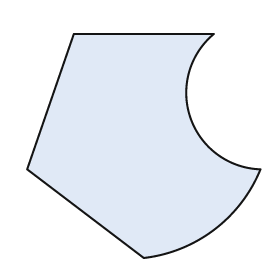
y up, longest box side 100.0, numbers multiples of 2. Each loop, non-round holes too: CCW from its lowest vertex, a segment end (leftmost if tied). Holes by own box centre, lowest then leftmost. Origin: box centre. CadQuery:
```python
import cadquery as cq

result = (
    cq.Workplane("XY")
    .moveTo(0.0, -48.0)
    .threePointArc((30.0, -36.0), (50.0, -10.0))
    .threePointArc((20.0, 12.0), (30.0, 48.0))
    .lineTo(-30.0, 48.0)
    .lineTo(-50.0, -10.0)
    .close()
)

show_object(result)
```